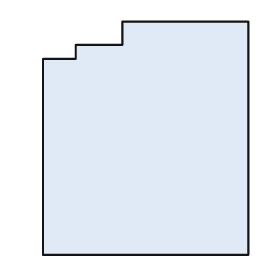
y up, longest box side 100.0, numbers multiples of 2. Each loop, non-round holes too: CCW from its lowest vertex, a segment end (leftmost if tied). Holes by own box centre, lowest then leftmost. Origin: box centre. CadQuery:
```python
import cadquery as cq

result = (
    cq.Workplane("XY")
    .moveTo(-44.0, -50.0)
    .lineTo(44.0, -50.0)
    .lineTo(44.0, 50.0)
    .lineTo(-10.0, 50.0)
    .lineTo(-10.0, 40.0)
    .lineTo(-30.0, 40.0)
    .lineTo(-30.0, 34.0)
    .lineTo(-44.0, 34.0)
    .close()
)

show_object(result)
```